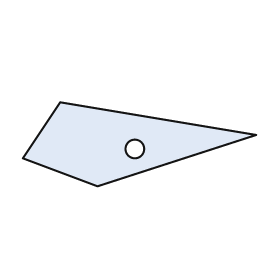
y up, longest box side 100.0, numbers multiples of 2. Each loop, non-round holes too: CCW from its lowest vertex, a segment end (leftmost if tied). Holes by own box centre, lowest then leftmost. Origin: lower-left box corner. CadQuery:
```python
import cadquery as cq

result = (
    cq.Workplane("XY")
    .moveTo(32.0, 0.0)
    .lineTo(100.0, 22.0)
    .lineTo(16.0, 36.0)
    .lineTo(0.0, 12.0)
    .close()
    .moveTo(48.0, 16.0)
    .circle(4.0)
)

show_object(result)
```